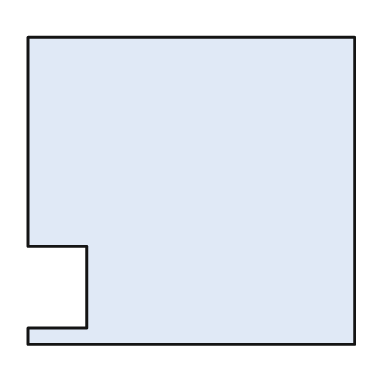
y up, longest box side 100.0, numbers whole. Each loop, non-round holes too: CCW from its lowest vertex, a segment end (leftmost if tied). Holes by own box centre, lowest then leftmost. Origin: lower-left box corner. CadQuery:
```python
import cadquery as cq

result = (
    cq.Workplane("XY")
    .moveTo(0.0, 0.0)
    .lineTo(100.0, 0.0)
    .lineTo(100.0, 94.0)
    .lineTo(0.0, 94.0)
    .lineTo(0.0, 30.0)
    .lineTo(18.0, 30.0)
    .lineTo(18.0, 5.0)
    .lineTo(0.0, 5.0)
    .close()
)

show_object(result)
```